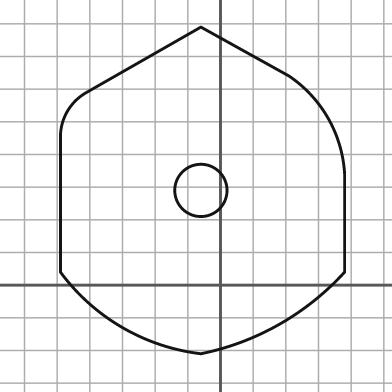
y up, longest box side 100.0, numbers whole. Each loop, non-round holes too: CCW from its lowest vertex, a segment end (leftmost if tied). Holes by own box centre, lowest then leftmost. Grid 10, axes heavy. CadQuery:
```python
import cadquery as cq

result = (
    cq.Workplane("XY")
    .moveTo(-6.0, -21.0)
    .threePointArc((18.0, -12.0), (38.0, 4.0))
    .lineTo(38.0, 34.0)
    .threePointArc((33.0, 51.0), (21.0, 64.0))
    .lineTo(-6.0, 79.0)
    .lineTo(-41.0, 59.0)
    .threePointArc((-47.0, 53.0), (-49.0, 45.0))
    .lineTo(-49.0, 4.0)
    .threePointArc((-30.0, -13.0), (-6.0, -21.0))
    .close()
    .moveTo(-6.0, 29.0)
    .circle(8.0)
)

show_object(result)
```